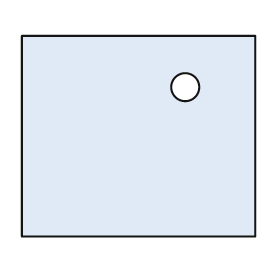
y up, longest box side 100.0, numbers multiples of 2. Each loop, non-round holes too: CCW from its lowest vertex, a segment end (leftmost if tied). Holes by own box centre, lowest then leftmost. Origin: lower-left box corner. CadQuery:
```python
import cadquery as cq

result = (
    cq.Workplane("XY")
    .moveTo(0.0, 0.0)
    .lineTo(100.0, 0.0)
    .lineTo(100.0, 86.0)
    .lineTo(0.0, 86.0)
    .close()
    .moveTo(70.0, 64.0)
    .circle(6.0)
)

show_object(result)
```